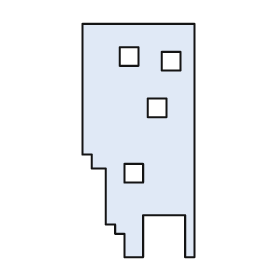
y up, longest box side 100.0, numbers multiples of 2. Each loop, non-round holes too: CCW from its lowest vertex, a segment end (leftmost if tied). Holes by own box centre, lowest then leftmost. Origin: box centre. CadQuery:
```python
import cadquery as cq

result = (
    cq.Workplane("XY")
    .moveTo(-6.0, -50.0)
    .lineTo(2.0, -50.0)
    .lineTo(2.0, -32.0)
    .lineTo(20.0, -32.0)
    .lineTo(20.0, -50.0)
    .lineTo(24.0, -50.0)
    .lineTo(24.0, 50.0)
    .lineTo(-24.0, 50.0)
    .lineTo(-24.0, -6.0)
    .lineTo(-20.0, -6.0)
    .lineTo(-20.0, -12.0)
    .lineTo(-14.0, -12.0)
    .lineTo(-14.0, -36.0)
    .lineTo(-10.0, -36.0)
    .lineTo(-10.0, -40.0)
    .lineTo(-6.0, -40.0)
    .close()
    .moveTo(-6.0, -18.0)
    .lineTo(2.0, -18.0)
    .lineTo(2.0, -10.0)
    .lineTo(-6.0, -10.0)
    .close()
    .moveTo(4.0, 10.0)
    .lineTo(12.0, 10.0)
    .lineTo(12.0, 18.0)
    .lineTo(4.0, 18.0)
    .close()
    .moveTo(10.0, 30.0)
    .lineTo(18.0, 30.0)
    .lineTo(18.0, 38.0)
    .lineTo(10.0, 38.0)
    .close()
    .moveTo(-8.0, 32.0)
    .lineTo(0.0, 32.0)
    .lineTo(0.0, 40.0)
    .lineTo(-8.0, 40.0)
    .close()
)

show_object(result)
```